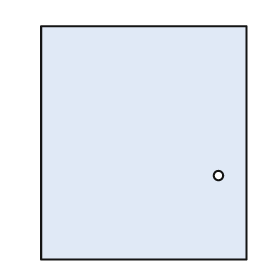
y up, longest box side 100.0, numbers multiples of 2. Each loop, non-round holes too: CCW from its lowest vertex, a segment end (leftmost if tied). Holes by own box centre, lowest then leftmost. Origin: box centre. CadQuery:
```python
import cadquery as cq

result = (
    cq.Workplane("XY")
    .moveTo(-44.0, -50.0)
    .lineTo(44.0, -50.0)
    .lineTo(44.0, 50.0)
    .lineTo(-44.0, 50.0)
    .close()
    .moveTo(32.0, -14.0)
    .circle(2.0)
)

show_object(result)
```